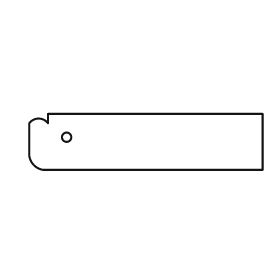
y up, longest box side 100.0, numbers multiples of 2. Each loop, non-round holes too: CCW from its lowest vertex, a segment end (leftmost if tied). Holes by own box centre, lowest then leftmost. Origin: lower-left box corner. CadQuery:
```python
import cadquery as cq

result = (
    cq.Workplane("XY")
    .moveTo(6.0, 0.0)
    .lineTo(100.0, 0.0)
    .lineTo(100.0, 24.0)
    .lineTo(8.0, 24.0)
    .lineTo(8.0, 20.0)
    .threePointArc((4.0, 22.0), (0.0, 20.0))
    .lineTo(0.0, 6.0)
    .threePointArc((2.0, 2.0), (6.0, 0.0))
    .close()
    .moveTo(16.0, 14.0)
    .circle(2.0)
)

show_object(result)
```